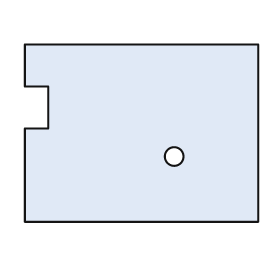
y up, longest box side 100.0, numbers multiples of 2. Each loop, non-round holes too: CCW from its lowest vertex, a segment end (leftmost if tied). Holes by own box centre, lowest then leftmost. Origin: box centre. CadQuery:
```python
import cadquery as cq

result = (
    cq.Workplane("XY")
    .moveTo(-50.0, -38.0)
    .lineTo(50.0, -38.0)
    .lineTo(50.0, 38.0)
    .lineTo(-50.0, 38.0)
    .lineTo(-50.0, 20.0)
    .lineTo(-40.0, 20.0)
    .lineTo(-40.0, 2.0)
    .lineTo(-50.0, 2.0)
    .close()
    .moveTo(14.0, -10.0)
    .circle(4.0)
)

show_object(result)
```